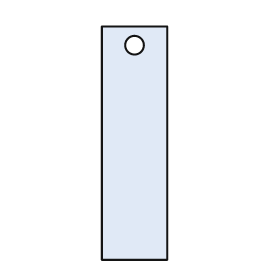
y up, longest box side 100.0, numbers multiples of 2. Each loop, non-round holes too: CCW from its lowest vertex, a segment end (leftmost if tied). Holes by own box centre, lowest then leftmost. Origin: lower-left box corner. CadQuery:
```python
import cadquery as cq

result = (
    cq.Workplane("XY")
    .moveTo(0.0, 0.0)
    .lineTo(28.0, 0.0)
    .lineTo(28.0, 100.0)
    .lineTo(0.0, 100.0)
    .close()
    .moveTo(14.0, 92.0)
    .circle(4.0)
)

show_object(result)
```